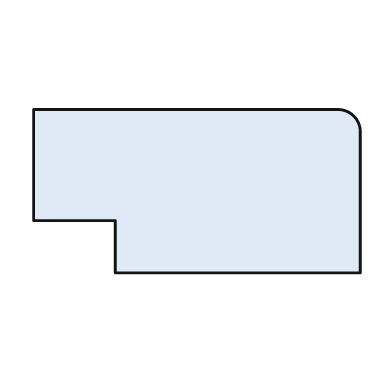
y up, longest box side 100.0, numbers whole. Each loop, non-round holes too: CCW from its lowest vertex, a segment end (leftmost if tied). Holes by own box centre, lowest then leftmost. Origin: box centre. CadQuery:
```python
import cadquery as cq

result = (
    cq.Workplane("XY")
    .moveTo(-25.0, -25.0)
    .lineTo(50.0, -25.0)
    .lineTo(50.0, 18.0)
    .threePointArc((48.0, 23.0), (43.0, 25.0))
    .lineTo(-50.0, 25.0)
    .lineTo(-50.0, -9.0)
    .lineTo(-25.0, -9.0)
    .close()
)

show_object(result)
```